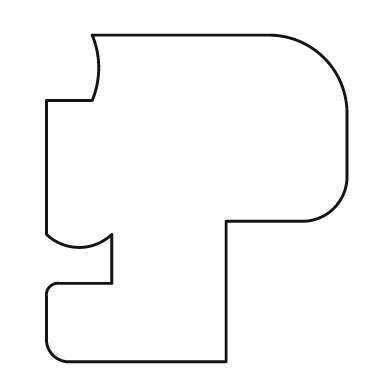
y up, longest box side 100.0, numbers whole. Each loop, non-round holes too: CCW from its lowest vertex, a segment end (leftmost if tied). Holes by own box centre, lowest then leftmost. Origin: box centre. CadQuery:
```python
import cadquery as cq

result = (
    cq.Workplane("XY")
    .moveTo(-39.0, -50.0)
    .lineTo(9.0, -50.0)
    .lineTo(9.0, -7.0)
    .lineTo(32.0, -7.0)
    .threePointArc((42.0, -3.0), (46.0, 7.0))
    .lineTo(46.0, 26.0)
    .threePointArc((39.0, 43.0), (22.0, 50.0))
    .lineTo(-32.0, 50.0)
    .threePointArc((-30.0, 40.0), (-32.0, 30.0))
    .lineTo(-46.0, 30.0)
    .lineTo(-46.0, -11.0)
    .threePointArc((-36.0, -15.0), (-26.0, -11.0))
    .lineTo(-26.0, -26.0)
    .lineTo(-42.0, -26.0)
    .threePointArc((-45.0, -27.0), (-46.0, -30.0))
    .lineTo(-46.0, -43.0)
    .threePointArc((-44.0, -48.0), (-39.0, -50.0))
    .close()
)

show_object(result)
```